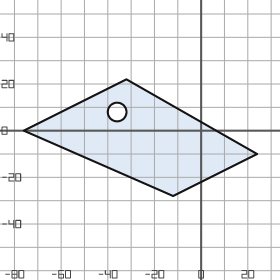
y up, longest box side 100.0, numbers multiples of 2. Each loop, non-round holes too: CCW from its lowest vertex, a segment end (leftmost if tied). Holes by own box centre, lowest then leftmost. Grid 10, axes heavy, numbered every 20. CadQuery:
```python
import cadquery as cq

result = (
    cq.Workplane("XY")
    .moveTo(-12.0, -28.0)
    .lineTo(24.0, -10.0)
    .lineTo(-32.0, 22.0)
    .lineTo(-76.0, 0.0)
    .close()
    .moveTo(-36.0, 8.0)
    .circle(4.0)
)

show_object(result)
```